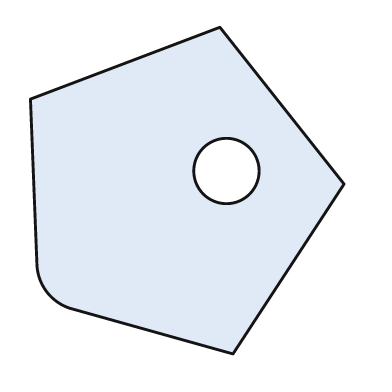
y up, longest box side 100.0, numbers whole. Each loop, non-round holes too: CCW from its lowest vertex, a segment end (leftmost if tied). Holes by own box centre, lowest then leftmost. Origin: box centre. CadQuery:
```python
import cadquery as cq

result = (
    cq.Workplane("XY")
    .moveTo(14.0, -50.0)
    .lineTo(48.0, 2.0)
    .lineTo(10.0, 50.0)
    .lineTo(-48.0, 28.0)
    .lineTo(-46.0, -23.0)
    .threePointArc((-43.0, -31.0), (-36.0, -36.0))
    .close()
    .moveTo(12.0, 6.0)
    .circle(10.0)
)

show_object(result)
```